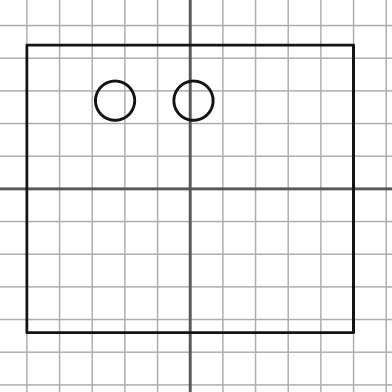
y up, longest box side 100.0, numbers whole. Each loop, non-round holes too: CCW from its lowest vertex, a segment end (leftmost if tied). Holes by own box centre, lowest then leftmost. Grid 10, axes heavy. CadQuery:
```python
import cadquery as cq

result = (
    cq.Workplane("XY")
    .moveTo(-50.0, -44.0)
    .lineTo(50.0, -44.0)
    .lineTo(50.0, 44.0)
    .lineTo(-50.0, 44.0)
    .close()
    .moveTo(-23.0, 27.0)
    .circle(6.0)
    .moveTo(1.0, 27.0)
    .circle(6.0)
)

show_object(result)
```